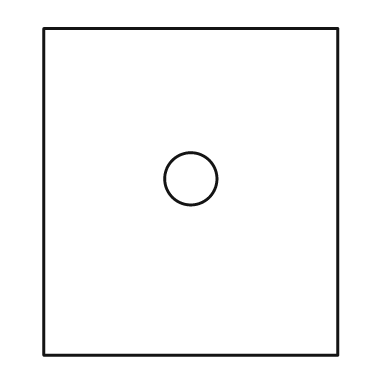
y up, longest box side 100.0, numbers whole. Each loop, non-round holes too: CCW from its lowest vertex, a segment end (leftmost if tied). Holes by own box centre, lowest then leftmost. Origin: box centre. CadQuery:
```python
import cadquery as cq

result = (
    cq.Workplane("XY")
    .moveTo(-45.0, -50.0)
    .lineTo(45.0, -50.0)
    .lineTo(45.0, 50.0)
    .lineTo(-45.0, 50.0)
    .close()
    .moveTo(0.0, 4.0)
    .circle(8.0)
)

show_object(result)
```